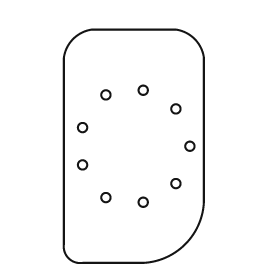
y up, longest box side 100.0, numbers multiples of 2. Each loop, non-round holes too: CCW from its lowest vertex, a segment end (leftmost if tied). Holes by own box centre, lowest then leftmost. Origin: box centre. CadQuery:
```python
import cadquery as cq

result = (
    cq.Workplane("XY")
    .moveTo(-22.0, -50.0)
    .lineTo(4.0, -50.0)
    .threePointArc((22.0, -42.0), (30.0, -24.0))
    .lineTo(30.0, 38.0)
    .threePointArc((26.0, 46.0), (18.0, 50.0))
    .lineTo(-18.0, 50.0)
    .threePointArc((-26.0, 46.0), (-30.0, 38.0))
    .lineTo(-30.0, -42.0)
    .threePointArc((-28.0, -48.0), (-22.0, -50.0))
    .close()
    .moveTo(4.0, -24.0)
    .circle(2.0)
    .moveTo(-12.0, -22.0)
    .circle(2.0)
    .moveTo(18.0, -16.0)
    .circle(2.0)
    .moveTo(-22.0, -8.0)
    .circle(2.0)
    .moveTo(24.0, 0.0)
    .circle(2.0)
    .moveTo(-22.0, 8.0)
    .circle(2.0)
    .moveTo(18.0, 16.0)
    .circle(2.0)
    .moveTo(-12.0, 22.0)
    .circle(2.0)
    .moveTo(4.0, 24.0)
    .circle(2.0)
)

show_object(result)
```